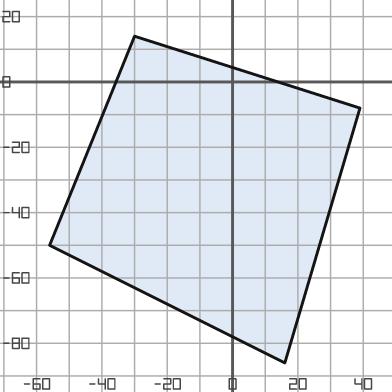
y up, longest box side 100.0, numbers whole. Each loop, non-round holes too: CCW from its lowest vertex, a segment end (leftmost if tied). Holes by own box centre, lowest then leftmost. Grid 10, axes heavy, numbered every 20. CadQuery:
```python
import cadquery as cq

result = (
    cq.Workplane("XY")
    .moveTo(16.0, -86.0)
    .lineTo(39.0, -8.0)
    .lineTo(-30.0, 14.0)
    .lineTo(-56.0, -50.0)
    .close()
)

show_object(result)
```